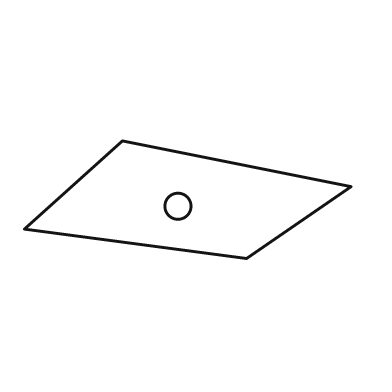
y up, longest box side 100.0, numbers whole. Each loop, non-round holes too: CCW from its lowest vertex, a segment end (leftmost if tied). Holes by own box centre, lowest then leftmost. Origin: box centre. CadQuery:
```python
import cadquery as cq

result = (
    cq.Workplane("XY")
    .moveTo(18.0, -18.0)
    .lineTo(50.0, 4.0)
    .lineTo(-20.0, 18.0)
    .lineTo(-50.0, -9.0)
    .close()
    .moveTo(-3.0, -2.0)
    .circle(4.0)
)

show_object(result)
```